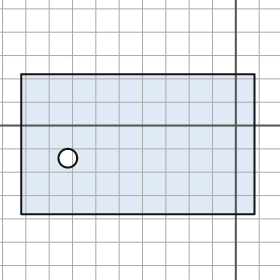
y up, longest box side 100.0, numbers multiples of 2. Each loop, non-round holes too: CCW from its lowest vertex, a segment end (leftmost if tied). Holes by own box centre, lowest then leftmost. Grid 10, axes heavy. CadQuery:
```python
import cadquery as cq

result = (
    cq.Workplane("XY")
    .moveTo(-92.0, -38.0)
    .lineTo(8.0, -38.0)
    .lineTo(8.0, 22.0)
    .lineTo(-92.0, 22.0)
    .close()
    .moveTo(-72.0, -14.0)
    .circle(4.0)
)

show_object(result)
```